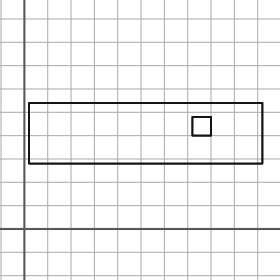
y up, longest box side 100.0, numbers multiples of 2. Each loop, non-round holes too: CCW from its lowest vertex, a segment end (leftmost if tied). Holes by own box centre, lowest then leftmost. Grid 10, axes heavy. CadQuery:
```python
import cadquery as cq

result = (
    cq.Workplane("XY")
    .moveTo(2.0, 28.0)
    .lineTo(102.0, 28.0)
    .lineTo(102.0, 54.0)
    .lineTo(2.0, 54.0)
    .close()
    .moveTo(72.0, 40.0)
    .lineTo(80.0, 40.0)
    .lineTo(80.0, 48.0)
    .lineTo(72.0, 48.0)
    .close()
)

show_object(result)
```